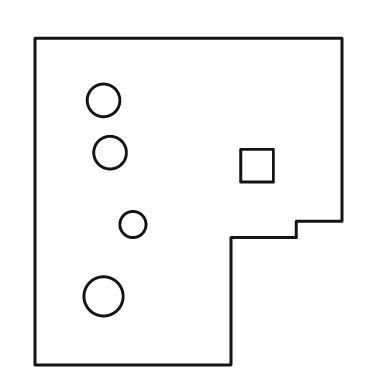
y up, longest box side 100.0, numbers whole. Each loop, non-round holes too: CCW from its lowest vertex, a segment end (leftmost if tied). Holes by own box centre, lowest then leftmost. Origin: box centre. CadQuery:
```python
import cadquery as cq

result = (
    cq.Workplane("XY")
    .moveTo(-47.0, -50.0)
    .lineTo(13.0, -50.0)
    .lineTo(13.0, -11.0)
    .lineTo(33.0, -11.0)
    .lineTo(33.0, -6.0)
    .lineTo(47.0, -6.0)
    .lineTo(47.0, 50.0)
    .lineTo(-47.0, 50.0)
    .close()
    .moveTo(-26.0, -29.0)
    .circle(6.0)
    .moveTo(-17.0, -7.0)
    .circle(4.0)
    .moveTo(16.0, 6.0)
    .lineTo(26.0, 6.0)
    .lineTo(26.0, 16.0)
    .lineTo(16.0, 16.0)
    .close()
    .moveTo(-24.0, 15.0)
    .circle(5.0)
    .moveTo(-26.0, 31.0)
    .circle(5.0)
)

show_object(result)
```